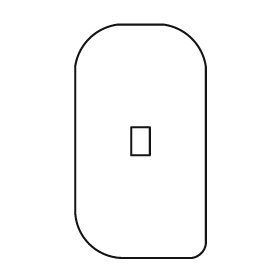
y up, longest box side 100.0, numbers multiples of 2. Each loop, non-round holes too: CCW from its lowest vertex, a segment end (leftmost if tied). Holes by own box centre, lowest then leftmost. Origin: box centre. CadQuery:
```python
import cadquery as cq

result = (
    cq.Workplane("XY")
    .moveTo(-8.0, -50.0)
    .lineTo(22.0, -50.0)
    .threePointArc((26.0, -48.0), (28.0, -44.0))
    .lineTo(28.0, 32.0)
    .threePointArc((22.0, 44.0), (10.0, 50.0))
    .lineTo(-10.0, 50.0)
    .threePointArc((-22.0, 44.0), (-28.0, 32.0))
    .lineTo(-28.0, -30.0)
    .threePointArc((-22.0, -44.0), (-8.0, -50.0))
    .close()
    .moveTo(-4.0, -6.0)
    .lineTo(4.0, -6.0)
    .lineTo(4.0, 6.0)
    .lineTo(-4.0, 6.0)
    .close()
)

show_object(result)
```